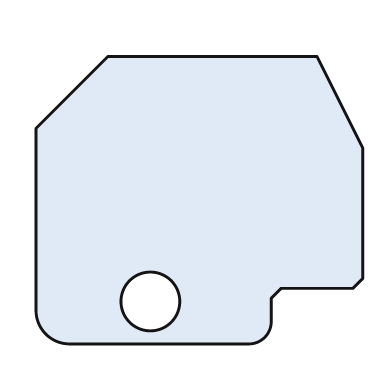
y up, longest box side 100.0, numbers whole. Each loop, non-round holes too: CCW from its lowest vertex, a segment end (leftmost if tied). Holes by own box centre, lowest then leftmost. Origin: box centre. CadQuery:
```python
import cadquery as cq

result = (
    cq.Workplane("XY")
    .moveTo(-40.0, -44.0)
    .lineTo(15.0, -44.0)
    .threePointArc((20.0, -42.0), (22.0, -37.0))
    .lineTo(22.0, -30.0)
    .lineTo(25.0, -27.0)
    .lineTo(47.0, -27.0)
    .lineTo(50.0, -24.0)
    .lineTo(50.0, 16.0)
    .lineTo(36.0, 44.0)
    .lineTo(-28.0, 44.0)
    .lineTo(-50.0, 22.0)
    .lineTo(-50.0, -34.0)
    .threePointArc((-47.0, -41.0), (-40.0, -44.0))
    .close()
    .moveTo(-15.0, -31.0)
    .circle(9.0)
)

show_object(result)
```